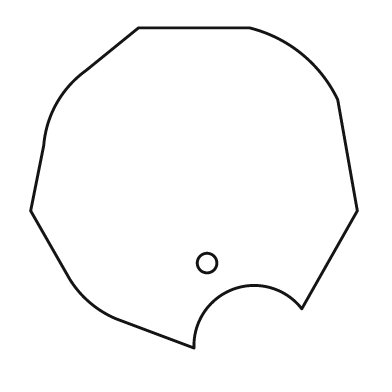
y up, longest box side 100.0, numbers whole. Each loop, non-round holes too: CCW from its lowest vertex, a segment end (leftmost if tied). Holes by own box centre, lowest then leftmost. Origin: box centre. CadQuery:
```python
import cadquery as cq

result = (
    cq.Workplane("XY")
    .moveTo(0.0, -49.0)
    .threePointArc((12.0, -31.0), (33.0, -37.0))
    .lineTo(50.0, -7.0)
    .lineTo(44.0, 27.0)
    .threePointArc((33.0, 41.0), (17.0, 49.0))
    .lineTo(-17.0, 49.0)
    .lineTo(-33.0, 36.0)
    .threePointArc((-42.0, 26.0), (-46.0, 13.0))
    .lineTo(-50.0, -7.0)
    .lineTo(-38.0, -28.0)
    .threePointArc((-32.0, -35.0), (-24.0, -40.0))
    .close()
    .moveTo(4.0, -23.0)
    .circle(3.0)
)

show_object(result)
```